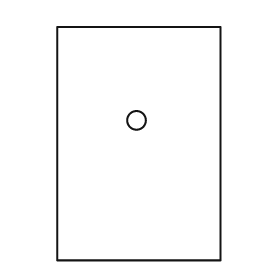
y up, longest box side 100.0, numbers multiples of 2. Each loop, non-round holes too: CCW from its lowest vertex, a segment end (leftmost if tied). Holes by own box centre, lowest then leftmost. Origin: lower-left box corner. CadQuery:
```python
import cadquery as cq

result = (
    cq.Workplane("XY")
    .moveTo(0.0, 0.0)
    .lineTo(70.0, 0.0)
    .lineTo(70.0, 100.0)
    .lineTo(0.0, 100.0)
    .close()
    .moveTo(34.0, 60.0)
    .circle(4.0)
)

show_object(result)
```